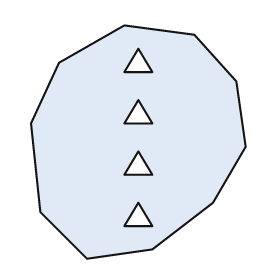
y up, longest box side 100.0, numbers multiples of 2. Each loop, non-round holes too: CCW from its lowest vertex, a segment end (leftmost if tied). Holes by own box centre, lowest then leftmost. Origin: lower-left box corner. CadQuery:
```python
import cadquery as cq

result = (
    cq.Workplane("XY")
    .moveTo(24.0, 0.0)
    .lineTo(52.0, 4.0)
    .lineTo(78.0, 24.0)
    .lineTo(92.0, 48.0)
    .lineTo(88.0, 76.0)
    .lineTo(70.0, 96.0)
    .lineTo(40.0, 100.0)
    .lineTo(12.0, 84.0)
    .lineTo(0.0, 58.0)
    .lineTo(4.0, 20.0)
    .close()
    .moveTo(40.0, 14.0)
    .lineTo(52.0, 14.0)
    .lineTo(46.0, 24.0)
    .close()
    .moveTo(40.0, 36.0)
    .lineTo(52.0, 36.0)
    .lineTo(46.0, 46.0)
    .close()
    .moveTo(40.0, 58.0)
    .lineTo(52.0, 58.0)
    .lineTo(46.0, 68.0)
    .close()
    .moveTo(40.0, 80.0)
    .lineTo(52.0, 80.0)
    .lineTo(46.0, 90.0)
    .close()
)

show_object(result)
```